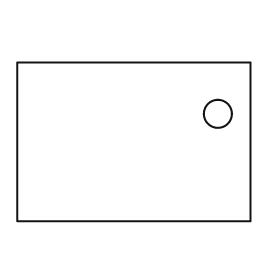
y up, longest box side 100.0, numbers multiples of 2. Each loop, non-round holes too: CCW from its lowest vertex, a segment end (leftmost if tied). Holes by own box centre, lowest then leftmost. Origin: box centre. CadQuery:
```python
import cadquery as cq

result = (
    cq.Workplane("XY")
    .moveTo(-50.0, -34.0)
    .lineTo(50.0, -34.0)
    .lineTo(50.0, 34.0)
    .lineTo(-50.0, 34.0)
    .close()
    .moveTo(36.0, 12.0)
    .circle(6.0)
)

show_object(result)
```